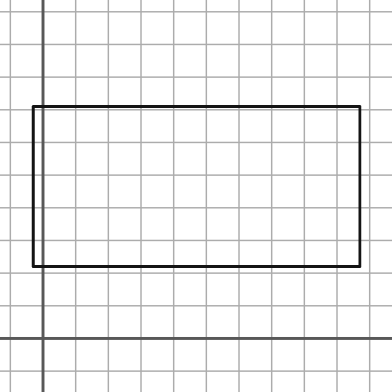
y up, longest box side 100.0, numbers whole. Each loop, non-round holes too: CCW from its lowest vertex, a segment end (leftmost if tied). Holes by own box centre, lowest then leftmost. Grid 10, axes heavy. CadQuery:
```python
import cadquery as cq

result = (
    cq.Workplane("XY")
    .moveTo(-3.0, 22.0)
    .lineTo(97.0, 22.0)
    .lineTo(97.0, 71.0)
    .lineTo(-3.0, 71.0)
    .close()
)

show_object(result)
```